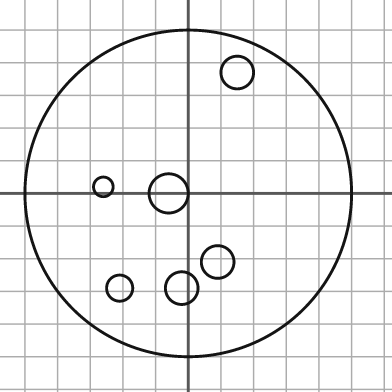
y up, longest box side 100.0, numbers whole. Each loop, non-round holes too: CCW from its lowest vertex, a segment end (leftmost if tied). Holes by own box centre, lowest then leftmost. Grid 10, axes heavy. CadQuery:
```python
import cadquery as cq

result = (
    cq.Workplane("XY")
    .moveTo(0.0, 0.0)
    .circle(50.0)
    .moveTo(-21.0, -29.0)
    .circle(4.0)
    .moveTo(-2.0, -29.0)
    .circle(5.0)
    .moveTo(9.0, -21.0)
    .circle(5.0)
    .moveTo(-6.0, 0.0)
    .circle(6.0)
    .moveTo(-26.0, 2.0)
    .circle(3.0)
    .moveTo(15.0, 37.0)
    .circle(5.0)
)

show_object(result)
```